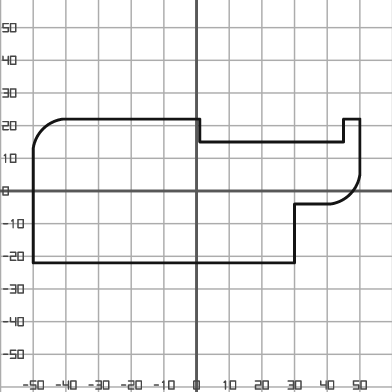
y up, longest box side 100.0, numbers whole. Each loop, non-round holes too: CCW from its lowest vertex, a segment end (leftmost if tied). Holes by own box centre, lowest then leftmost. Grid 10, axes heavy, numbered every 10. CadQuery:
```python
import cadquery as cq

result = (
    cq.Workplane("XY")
    .moveTo(-50.0, -22.0)
    .lineTo(30.0, -22.0)
    .lineTo(30.0, -4.0)
    .lineTo(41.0, -4.0)
    .threePointArc((47.0, -1.0), (50.0, 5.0))
    .lineTo(50.0, 22.0)
    .lineTo(45.0, 22.0)
    .lineTo(45.0, 15.0)
    .lineTo(1.0, 15.0)
    .lineTo(1.0, 22.0)
    .lineTo(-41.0, 22.0)
    .threePointArc((-47.0, 19.0), (-50.0, 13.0))
    .close()
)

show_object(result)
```